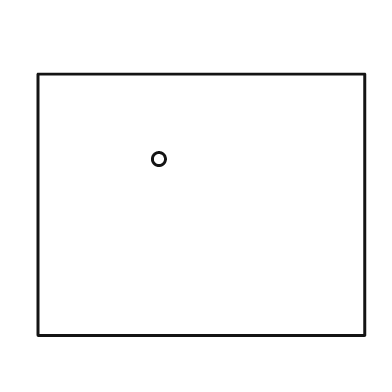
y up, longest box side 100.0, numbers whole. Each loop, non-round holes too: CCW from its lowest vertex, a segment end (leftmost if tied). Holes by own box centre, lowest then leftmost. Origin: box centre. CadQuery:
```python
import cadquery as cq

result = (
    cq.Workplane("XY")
    .moveTo(-50.0, -40.0)
    .lineTo(50.0, -40.0)
    .lineTo(50.0, 40.0)
    .lineTo(-50.0, 40.0)
    .close()
    .moveTo(-13.0, 14.0)
    .circle(2.0)
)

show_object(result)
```